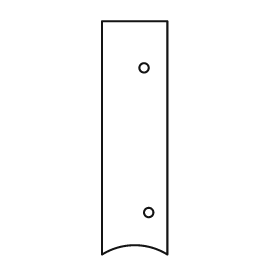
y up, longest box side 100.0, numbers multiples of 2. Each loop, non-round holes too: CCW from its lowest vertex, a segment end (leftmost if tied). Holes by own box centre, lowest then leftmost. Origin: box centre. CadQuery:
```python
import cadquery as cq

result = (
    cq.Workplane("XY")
    .moveTo(-14.0, -50.0)
    .threePointArc((0.0, -46.0), (14.0, -50.0))
    .lineTo(14.0, 50.0)
    .lineTo(-14.0, 50.0)
    .close()
    .moveTo(6.0, -32.0)
    .circle(2.0)
    .moveTo(4.0, 30.0)
    .circle(2.0)
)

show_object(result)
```